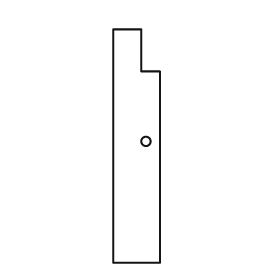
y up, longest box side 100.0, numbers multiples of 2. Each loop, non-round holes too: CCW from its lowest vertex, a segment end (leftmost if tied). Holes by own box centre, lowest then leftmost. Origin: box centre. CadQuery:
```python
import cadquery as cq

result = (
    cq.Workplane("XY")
    .moveTo(-10.0, -50.0)
    .lineTo(10.0, -50.0)
    .lineTo(10.0, 32.0)
    .lineTo(2.0, 32.0)
    .lineTo(2.0, 50.0)
    .lineTo(-10.0, 50.0)
    .close()
    .moveTo(4.0, 2.0)
    .circle(2.0)
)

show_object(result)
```